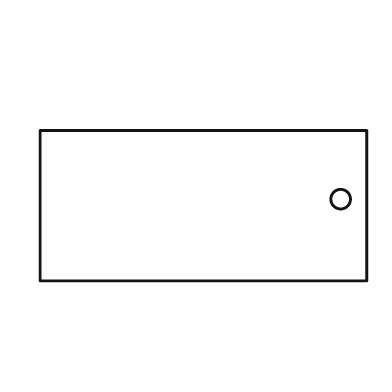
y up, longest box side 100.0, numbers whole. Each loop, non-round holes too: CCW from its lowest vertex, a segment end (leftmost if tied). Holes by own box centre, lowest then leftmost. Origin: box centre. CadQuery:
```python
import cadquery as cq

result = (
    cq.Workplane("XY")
    .moveTo(-50.0, -23.0)
    .lineTo(50.0, -23.0)
    .lineTo(50.0, 23.0)
    .lineTo(-50.0, 23.0)
    .close()
    .moveTo(42.0, 2.0)
    .circle(3.0)
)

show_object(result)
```